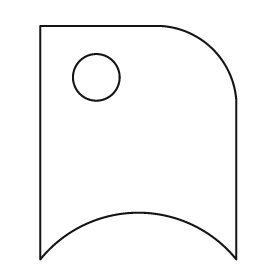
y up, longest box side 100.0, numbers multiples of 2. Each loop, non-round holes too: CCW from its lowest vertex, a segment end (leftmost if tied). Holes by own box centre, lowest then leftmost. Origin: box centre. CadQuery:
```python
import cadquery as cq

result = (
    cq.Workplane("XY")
    .moveTo(-42.0, -50.0)
    .threePointArc((0.0, -30.0), (42.0, -50.0))
    .lineTo(42.0, 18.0)
    .threePointArc((32.0, 40.0), (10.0, 50.0))
    .lineTo(-42.0, 50.0)
    .close()
    .moveTo(-18.0, 28.0)
    .circle(10.0)
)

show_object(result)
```